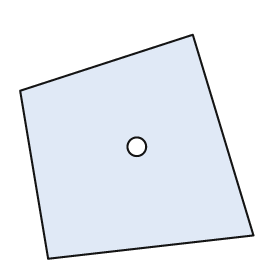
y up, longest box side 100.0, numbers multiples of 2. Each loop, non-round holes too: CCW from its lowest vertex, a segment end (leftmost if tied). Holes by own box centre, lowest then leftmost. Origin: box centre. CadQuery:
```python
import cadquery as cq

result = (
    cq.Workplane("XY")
    .moveTo(-38.0, -48.0)
    .lineTo(50.0, -38.0)
    .lineTo(24.0, 48.0)
    .lineTo(-50.0, 24.0)
    .close()
    .moveTo(0.0, 0.0)
    .circle(4.0)
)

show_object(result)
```